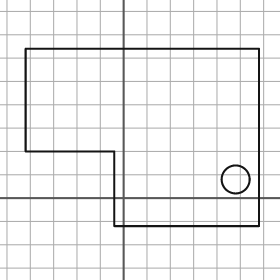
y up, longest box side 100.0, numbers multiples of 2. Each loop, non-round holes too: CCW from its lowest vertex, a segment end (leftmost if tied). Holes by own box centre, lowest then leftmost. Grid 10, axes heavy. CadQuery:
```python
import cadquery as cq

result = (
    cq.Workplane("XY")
    .moveTo(-4.0, -12.0)
    .lineTo(58.0, -12.0)
    .lineTo(58.0, 64.0)
    .lineTo(-42.0, 64.0)
    .lineTo(-42.0, 20.0)
    .lineTo(-4.0, 20.0)
    .close()
    .moveTo(48.0, 8.0)
    .circle(6.0)
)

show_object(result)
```